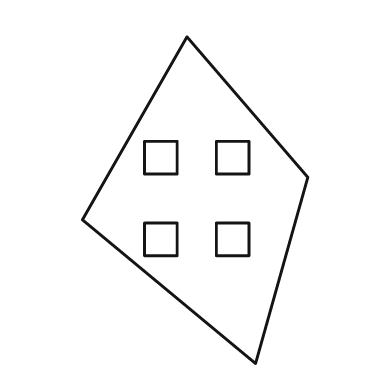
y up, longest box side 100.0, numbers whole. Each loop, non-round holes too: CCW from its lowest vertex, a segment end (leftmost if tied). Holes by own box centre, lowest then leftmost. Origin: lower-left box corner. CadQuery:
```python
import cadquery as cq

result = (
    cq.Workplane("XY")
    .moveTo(53.0, 0.0)
    .lineTo(69.0, 57.0)
    .lineTo(32.0, 100.0)
    .lineTo(0.0, 44.0)
    .close()
    .moveTo(19.0, 33.0)
    .lineTo(29.0, 33.0)
    .lineTo(29.0, 43.0)
    .lineTo(19.0, 43.0)
    .close()
    .moveTo(41.0, 33.0)
    .lineTo(51.0, 33.0)
    .lineTo(51.0, 43.0)
    .lineTo(41.0, 43.0)
    .close()
    .moveTo(19.0, 58.0)
    .lineTo(29.0, 58.0)
    .lineTo(29.0, 68.0)
    .lineTo(19.0, 68.0)
    .close()
    .moveTo(41.0, 58.0)
    .lineTo(51.0, 58.0)
    .lineTo(51.0, 68.0)
    .lineTo(41.0, 68.0)
    .close()
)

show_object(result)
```